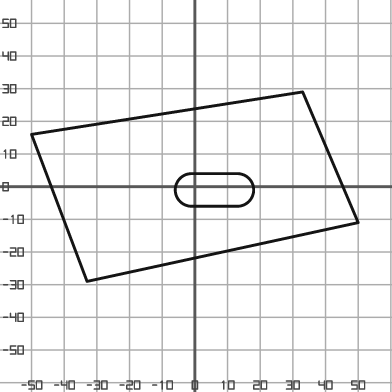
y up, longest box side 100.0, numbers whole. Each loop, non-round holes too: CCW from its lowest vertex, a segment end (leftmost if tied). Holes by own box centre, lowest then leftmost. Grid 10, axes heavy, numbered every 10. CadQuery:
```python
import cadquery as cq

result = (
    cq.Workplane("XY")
    .moveTo(-33.0, -29.0)
    .lineTo(50.0, -11.0)
    .lineTo(33.0, 29.0)
    .lineTo(-50.0, 16.0)
    .close()
    .moveTo(-1.0, -6.0)
    .lineTo(13.0, -6.0)
    .threePointArc((18.0, -1.0), (13.0, 4.0))
    .lineTo(-1.0, 4.0)
    .threePointArc((-6.0, -1.0), (-1.0, -6.0))
    .close()
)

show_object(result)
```